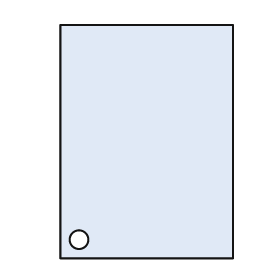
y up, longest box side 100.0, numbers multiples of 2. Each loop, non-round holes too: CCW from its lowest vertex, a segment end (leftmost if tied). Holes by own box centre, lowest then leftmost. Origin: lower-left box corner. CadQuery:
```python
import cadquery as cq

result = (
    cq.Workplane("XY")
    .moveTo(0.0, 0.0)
    .lineTo(74.0, 0.0)
    .lineTo(74.0, 100.0)
    .lineTo(0.0, 100.0)
    .close()
    .moveTo(8.0, 8.0)
    .circle(4.0)
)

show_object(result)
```